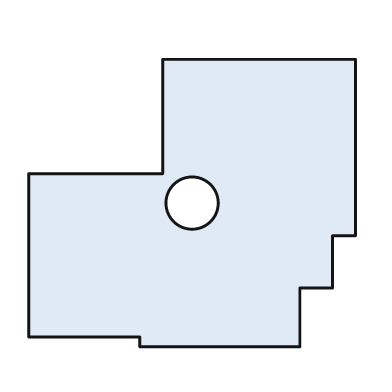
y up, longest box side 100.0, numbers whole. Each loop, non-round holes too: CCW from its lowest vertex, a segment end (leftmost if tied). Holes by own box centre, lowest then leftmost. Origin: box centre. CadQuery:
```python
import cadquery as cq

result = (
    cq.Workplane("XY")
    .moveTo(-16.0, -44.0)
    .lineTo(33.0, -44.0)
    .lineTo(33.0, -26.0)
    .lineTo(43.0, -26.0)
    .lineTo(43.0, -10.0)
    .lineTo(50.0, -10.0)
    .lineTo(50.0, 44.0)
    .lineTo(-9.0, 44.0)
    .lineTo(-9.0, 9.0)
    .lineTo(-50.0, 9.0)
    .lineTo(-50.0, -41.0)
    .lineTo(-16.0, -41.0)
    .close()
    .moveTo(0.0, 0.0)
    .circle(8.0)
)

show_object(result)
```